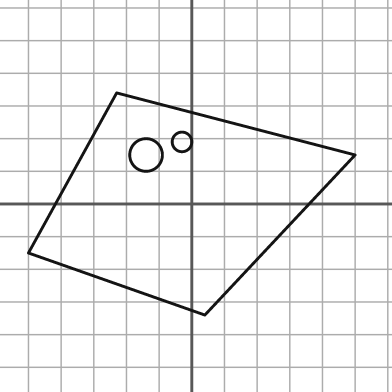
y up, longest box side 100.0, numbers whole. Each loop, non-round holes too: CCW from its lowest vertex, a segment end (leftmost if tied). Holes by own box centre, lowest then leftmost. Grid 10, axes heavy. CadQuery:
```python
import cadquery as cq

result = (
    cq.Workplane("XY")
    .moveTo(4.0, -34.0)
    .lineTo(50.0, 15.0)
    .lineTo(-23.0, 34.0)
    .lineTo(-50.0, -15.0)
    .close()
    .moveTo(-14.0, 15.0)
    .circle(5.0)
    .moveTo(-3.0, 19.0)
    .circle(3.0)
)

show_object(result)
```